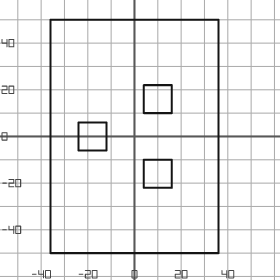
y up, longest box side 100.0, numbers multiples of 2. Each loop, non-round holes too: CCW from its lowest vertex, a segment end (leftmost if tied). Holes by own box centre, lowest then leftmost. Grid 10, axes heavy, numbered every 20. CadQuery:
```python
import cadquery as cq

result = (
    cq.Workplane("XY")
    .moveTo(-36.0, -50.0)
    .lineTo(36.0, -50.0)
    .lineTo(36.0, 50.0)
    .lineTo(-36.0, 50.0)
    .close()
    .moveTo(4.0, -22.0)
    .lineTo(16.0, -22.0)
    .lineTo(16.0, -10.0)
    .lineTo(4.0, -10.0)
    .close()
    .moveTo(-24.0, -6.0)
    .lineTo(-12.0, -6.0)
    .lineTo(-12.0, 6.0)
    .lineTo(-24.0, 6.0)
    .close()
    .moveTo(4.0, 10.0)
    .lineTo(16.0, 10.0)
    .lineTo(16.0, 22.0)
    .lineTo(4.0, 22.0)
    .close()
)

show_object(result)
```